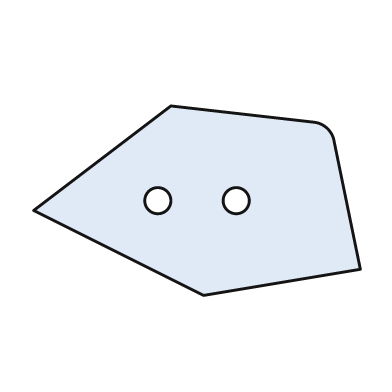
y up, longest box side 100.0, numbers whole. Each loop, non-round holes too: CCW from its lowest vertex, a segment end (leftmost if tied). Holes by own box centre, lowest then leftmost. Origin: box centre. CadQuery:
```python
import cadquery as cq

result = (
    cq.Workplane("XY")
    .moveTo(2.0, -29.0)
    .lineTo(50.0, -21.0)
    .lineTo(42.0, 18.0)
    .threePointArc((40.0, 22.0), (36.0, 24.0))
    .lineTo(-8.0, 29.0)
    .lineTo(-50.0, -3.0)
    .close()
    .moveTo(-12.0, 0.0)
    .circle(4.0)
    .moveTo(12.0, 0.0)
    .circle(4.0)
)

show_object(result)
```